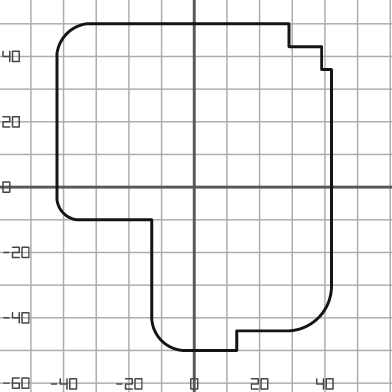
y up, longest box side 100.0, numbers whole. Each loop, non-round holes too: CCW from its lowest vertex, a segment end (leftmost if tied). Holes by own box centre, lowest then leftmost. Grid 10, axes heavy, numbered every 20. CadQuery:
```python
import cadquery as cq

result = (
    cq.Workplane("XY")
    .moveTo(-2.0, -50.0)
    .lineTo(13.0, -50.0)
    .lineTo(13.0, -44.0)
    .lineTo(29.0, -44.0)
    .threePointArc((38.0, -40.0), (42.0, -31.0))
    .lineTo(42.0, 36.0)
    .lineTo(39.0, 36.0)
    .lineTo(39.0, 43.0)
    .lineTo(29.0, 43.0)
    .lineTo(29.0, 50.0)
    .lineTo(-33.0, 50.0)
    .threePointArc((-39.0, 47.0), (-42.0, 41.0))
    .lineTo(-42.0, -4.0)
    .threePointArc((-40.0, -8.0), (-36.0, -10.0))
    .lineTo(-13.0, -10.0)
    .lineTo(-13.0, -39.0)
    .threePointArc((-10.0, -47.0), (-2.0, -50.0))
    .close()
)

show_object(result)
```